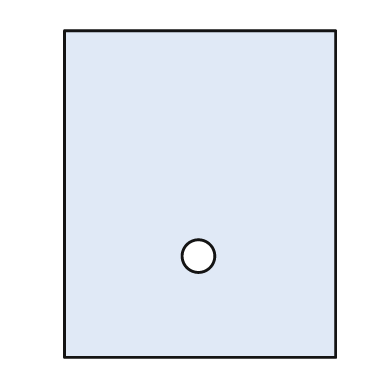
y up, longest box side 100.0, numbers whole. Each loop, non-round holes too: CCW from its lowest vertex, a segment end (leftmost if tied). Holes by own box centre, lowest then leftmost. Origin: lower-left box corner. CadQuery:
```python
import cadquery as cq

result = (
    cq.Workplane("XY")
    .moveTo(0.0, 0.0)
    .lineTo(83.0, 0.0)
    .lineTo(83.0, 100.0)
    .lineTo(0.0, 100.0)
    .close()
    .moveTo(41.0, 31.0)
    .circle(5.0)
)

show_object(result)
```